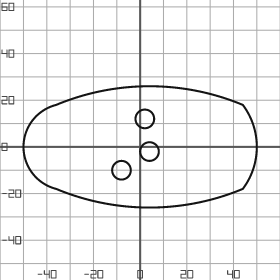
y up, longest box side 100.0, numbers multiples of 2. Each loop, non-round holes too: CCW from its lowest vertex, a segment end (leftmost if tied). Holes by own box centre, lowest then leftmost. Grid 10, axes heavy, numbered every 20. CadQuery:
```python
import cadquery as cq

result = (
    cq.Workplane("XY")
    .moveTo(-36.0, -18.0)
    .threePointArc((4.0, -26.0), (44.0, -18.0))
    .threePointArc((50.0, 0.0), (44.0, 18.0))
    .threePointArc((4.0, 26.0), (-36.0, 18.0))
    .threePointArc((-50.0, 0.0), (-36.0, -18.0))
    .close()
    .moveTo(-8.0, -10.0)
    .circle(4.0)
    .moveTo(4.0, -2.0)
    .circle(4.0)
    .moveTo(2.0, 12.0)
    .circle(4.0)
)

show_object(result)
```